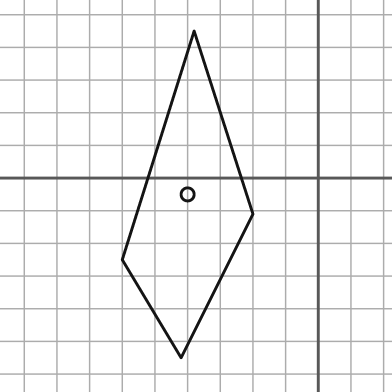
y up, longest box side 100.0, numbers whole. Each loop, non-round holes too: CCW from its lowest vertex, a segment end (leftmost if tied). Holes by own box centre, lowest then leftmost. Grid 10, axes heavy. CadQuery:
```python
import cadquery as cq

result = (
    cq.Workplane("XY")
    .moveTo(-42.0, -55.0)
    .lineTo(-20.0, -11.0)
    .lineTo(-38.0, 45.0)
    .lineTo(-60.0, -25.0)
    .close()
    .moveTo(-40.0, -5.0)
    .circle(2.0)
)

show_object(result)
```